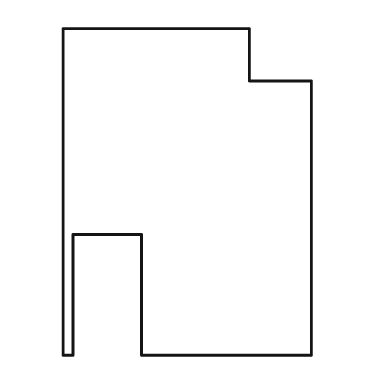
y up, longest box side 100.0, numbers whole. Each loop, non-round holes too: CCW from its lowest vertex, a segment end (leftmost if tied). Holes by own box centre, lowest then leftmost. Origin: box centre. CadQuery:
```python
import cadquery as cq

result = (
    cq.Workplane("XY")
    .moveTo(-38.0, -50.0)
    .lineTo(-35.0, -50.0)
    .lineTo(-35.0, -13.0)
    .lineTo(-14.0, -13.0)
    .lineTo(-14.0, -50.0)
    .lineTo(38.0, -50.0)
    .lineTo(38.0, 34.0)
    .lineTo(19.0, 34.0)
    .lineTo(19.0, 50.0)
    .lineTo(-38.0, 50.0)
    .close()
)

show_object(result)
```